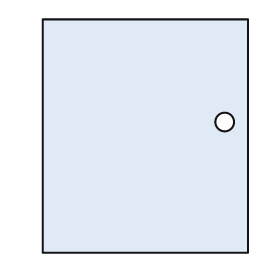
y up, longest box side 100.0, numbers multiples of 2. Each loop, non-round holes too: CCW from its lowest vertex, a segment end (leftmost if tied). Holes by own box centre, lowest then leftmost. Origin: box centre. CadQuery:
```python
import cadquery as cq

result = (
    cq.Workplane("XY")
    .moveTo(-44.0, -50.0)
    .lineTo(44.0, -50.0)
    .lineTo(44.0, 50.0)
    .lineTo(-44.0, 50.0)
    .close()
    .moveTo(34.0, 6.0)
    .circle(4.0)
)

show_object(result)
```